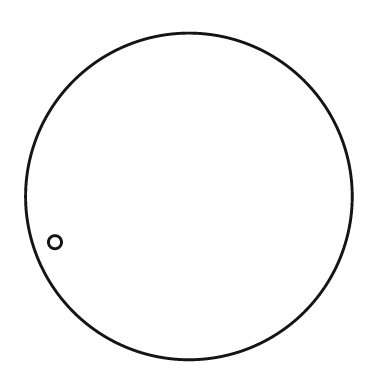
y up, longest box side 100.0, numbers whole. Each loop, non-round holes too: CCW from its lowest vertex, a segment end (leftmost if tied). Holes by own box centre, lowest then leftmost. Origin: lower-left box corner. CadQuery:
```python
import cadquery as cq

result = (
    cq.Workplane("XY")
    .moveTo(50.0, 50.0)
    .circle(50.0)
    .moveTo(9.0, 36.0)
    .circle(2.0)
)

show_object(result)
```